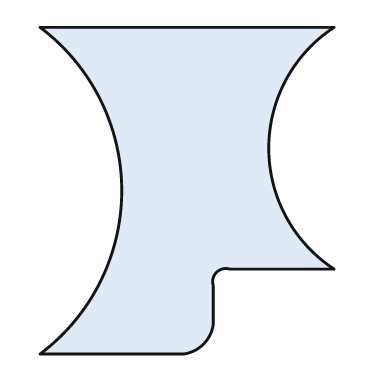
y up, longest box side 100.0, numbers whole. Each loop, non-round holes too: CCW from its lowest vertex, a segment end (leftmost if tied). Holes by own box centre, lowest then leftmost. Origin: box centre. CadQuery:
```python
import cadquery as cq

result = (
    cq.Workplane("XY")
    .moveTo(-45.0, -50.0)
    .lineTo(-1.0, -50.0)
    .threePointArc((5.0, -47.0), (8.0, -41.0))
    .lineTo(8.0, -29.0)
    .threePointArc((9.0, -25.0), (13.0, -24.0))
    .lineTo(45.0, -24.0)
    .threePointArc((25.0, 13.0), (45.0, 50.0))
    .lineTo(-45.0, 50.0)
    .threePointArc((-20.0, 0.0), (-45.0, -50.0))
    .close()
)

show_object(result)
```